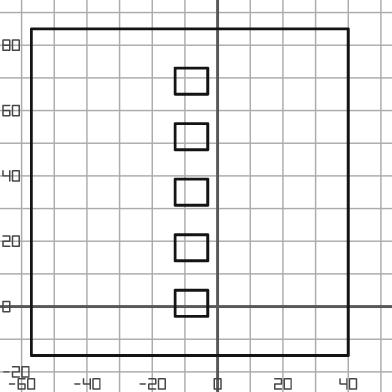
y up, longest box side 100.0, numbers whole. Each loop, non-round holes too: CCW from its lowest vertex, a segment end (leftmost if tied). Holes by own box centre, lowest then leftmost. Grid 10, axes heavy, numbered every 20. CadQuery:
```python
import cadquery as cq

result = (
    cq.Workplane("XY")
    .moveTo(-57.0, -15.0)
    .lineTo(40.0, -15.0)
    .lineTo(40.0, 85.0)
    .lineTo(-57.0, 85.0)
    .close()
    .moveTo(-13.0, -3.0)
    .lineTo(-3.0, -3.0)
    .lineTo(-3.0, 5.0)
    .lineTo(-13.0, 5.0)
    .close()
    .moveTo(-13.0, 14.0)
    .lineTo(-3.0, 14.0)
    .lineTo(-3.0, 22.0)
    .lineTo(-13.0, 22.0)
    .close()
    .moveTo(-13.0, 31.0)
    .lineTo(-3.0, 31.0)
    .lineTo(-3.0, 39.0)
    .lineTo(-13.0, 39.0)
    .close()
    .moveTo(-13.0, 48.0)
    .lineTo(-3.0, 48.0)
    .lineTo(-3.0, 56.0)
    .lineTo(-13.0, 56.0)
    .close()
    .moveTo(-13.0, 65.0)
    .lineTo(-3.0, 65.0)
    .lineTo(-3.0, 73.0)
    .lineTo(-13.0, 73.0)
    .close()
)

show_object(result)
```